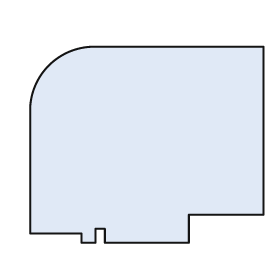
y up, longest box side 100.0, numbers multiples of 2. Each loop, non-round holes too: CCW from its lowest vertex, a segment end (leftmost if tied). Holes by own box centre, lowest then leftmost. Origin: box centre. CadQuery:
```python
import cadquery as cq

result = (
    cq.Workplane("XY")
    .moveTo(-28.0, -42.0)
    .lineTo(-22.0, -42.0)
    .lineTo(-22.0, -36.0)
    .lineTo(-18.0, -36.0)
    .lineTo(-18.0, -42.0)
    .lineTo(18.0, -42.0)
    .lineTo(18.0, -30.0)
    .lineTo(50.0, -30.0)
    .lineTo(50.0, 42.0)
    .lineTo(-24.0, 42.0)
    .threePointArc((-42.0, 34.0), (-50.0, 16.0))
    .lineTo(-50.0, -38.0)
    .lineTo(-28.0, -38.0)
    .close()
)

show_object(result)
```